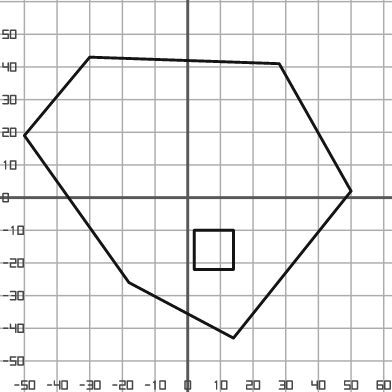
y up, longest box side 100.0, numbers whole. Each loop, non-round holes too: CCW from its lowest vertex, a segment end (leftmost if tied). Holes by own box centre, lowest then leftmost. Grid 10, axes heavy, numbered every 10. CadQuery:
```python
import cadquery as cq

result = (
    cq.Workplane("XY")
    .moveTo(14.0, -43.0)
    .lineTo(50.0, 2.0)
    .lineTo(28.0, 41.0)
    .lineTo(-30.0, 43.0)
    .lineTo(-50.0, 19.0)
    .lineTo(-18.0, -26.0)
    .close()
    .moveTo(2.0, -22.0)
    .lineTo(14.0, -22.0)
    .lineTo(14.0, -10.0)
    .lineTo(2.0, -10.0)
    .close()
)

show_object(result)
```